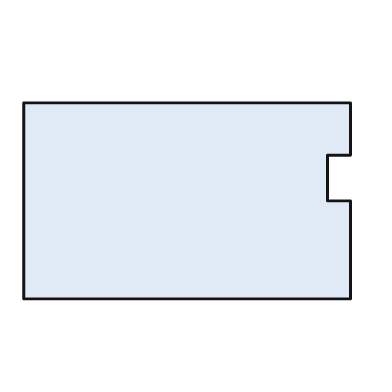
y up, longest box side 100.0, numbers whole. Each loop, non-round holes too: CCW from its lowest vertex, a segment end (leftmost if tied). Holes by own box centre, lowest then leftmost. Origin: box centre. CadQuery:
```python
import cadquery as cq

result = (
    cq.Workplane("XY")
    .moveTo(-50.0, -30.0)
    .lineTo(50.0, -30.0)
    .lineTo(50.0, 0.0)
    .lineTo(43.0, 0.0)
    .lineTo(43.0, 14.0)
    .lineTo(50.0, 14.0)
    .lineTo(50.0, 30.0)
    .lineTo(-50.0, 30.0)
    .close()
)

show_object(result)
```